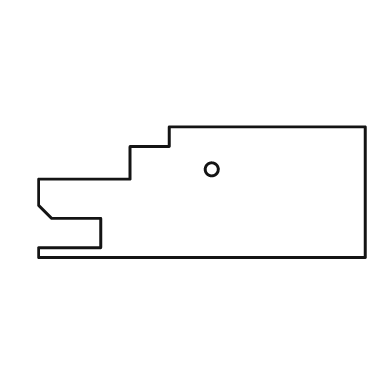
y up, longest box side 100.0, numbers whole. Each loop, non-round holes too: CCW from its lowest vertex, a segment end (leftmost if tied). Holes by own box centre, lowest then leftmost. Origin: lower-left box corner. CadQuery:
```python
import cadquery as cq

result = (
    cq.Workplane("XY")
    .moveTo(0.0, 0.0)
    .lineTo(100.0, 0.0)
    .lineTo(100.0, 40.0)
    .lineTo(40.0, 40.0)
    .lineTo(40.0, 34.0)
    .lineTo(28.0, 34.0)
    .lineTo(28.0, 24.0)
    .lineTo(0.0, 24.0)
    .lineTo(0.0, 16.0)
    .lineTo(4.0, 12.0)
    .lineTo(19.0, 12.0)
    .lineTo(19.0, 3.0)
    .lineTo(0.0, 3.0)
    .close()
    .moveTo(53.0, 27.0)
    .circle(2.0)
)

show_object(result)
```